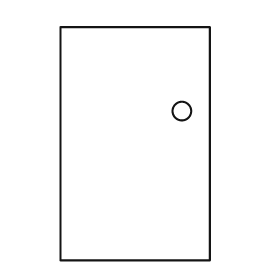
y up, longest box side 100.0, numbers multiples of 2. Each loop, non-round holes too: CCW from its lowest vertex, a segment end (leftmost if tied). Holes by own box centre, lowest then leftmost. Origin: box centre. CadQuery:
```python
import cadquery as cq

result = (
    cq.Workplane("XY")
    .moveTo(-32.0, -50.0)
    .lineTo(32.0, -50.0)
    .lineTo(32.0, 50.0)
    .lineTo(-32.0, 50.0)
    .close()
    .moveTo(20.0, 14.0)
    .circle(4.0)
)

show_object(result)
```